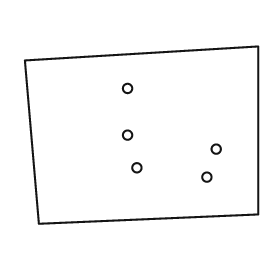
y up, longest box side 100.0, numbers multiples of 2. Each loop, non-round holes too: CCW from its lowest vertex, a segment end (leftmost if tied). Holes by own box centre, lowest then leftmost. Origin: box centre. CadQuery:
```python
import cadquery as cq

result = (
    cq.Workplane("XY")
    .moveTo(-44.0, -38.0)
    .lineTo(50.0, -34.0)
    .lineTo(50.0, 38.0)
    .lineTo(-50.0, 32.0)
    .close()
    .moveTo(28.0, -18.0)
    .circle(2.0)
    .moveTo(-2.0, -14.0)
    .circle(2.0)
    .moveTo(32.0, -6.0)
    .circle(2.0)
    .moveTo(-6.0, 0.0)
    .circle(2.0)
    .moveTo(-6.0, 20.0)
    .circle(2.0)
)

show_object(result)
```